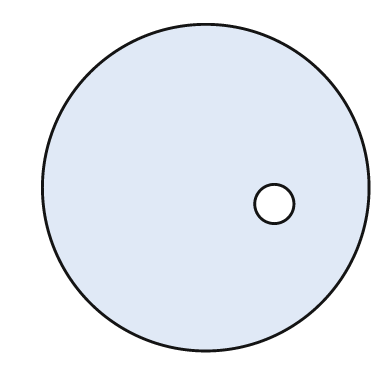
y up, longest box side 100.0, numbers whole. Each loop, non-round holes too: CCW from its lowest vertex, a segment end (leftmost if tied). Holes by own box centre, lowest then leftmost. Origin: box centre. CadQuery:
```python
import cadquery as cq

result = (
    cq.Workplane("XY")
    .moveTo(0.0, 0.0)
    .circle(50.0)
    .moveTo(21.0, -5.0)
    .circle(6.0)
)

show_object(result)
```